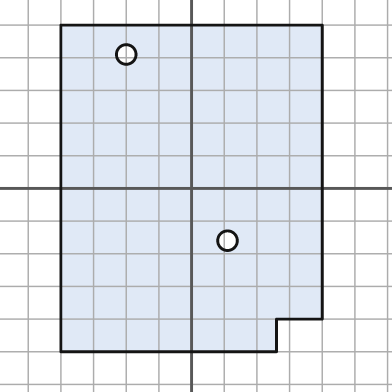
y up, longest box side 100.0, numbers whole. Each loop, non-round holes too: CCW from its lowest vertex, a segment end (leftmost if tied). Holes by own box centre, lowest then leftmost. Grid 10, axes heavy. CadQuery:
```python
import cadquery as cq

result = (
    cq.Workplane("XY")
    .moveTo(-40.0, -50.0)
    .lineTo(26.0, -50.0)
    .lineTo(26.0, -40.0)
    .lineTo(40.0, -40.0)
    .lineTo(40.0, 50.0)
    .lineTo(-40.0, 50.0)
    .close()
    .moveTo(11.0, -16.0)
    .circle(3.0)
    .moveTo(-20.0, 41.0)
    .circle(3.0)
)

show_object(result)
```